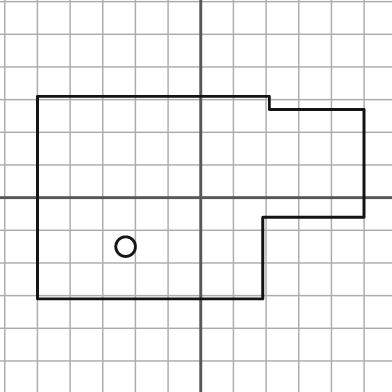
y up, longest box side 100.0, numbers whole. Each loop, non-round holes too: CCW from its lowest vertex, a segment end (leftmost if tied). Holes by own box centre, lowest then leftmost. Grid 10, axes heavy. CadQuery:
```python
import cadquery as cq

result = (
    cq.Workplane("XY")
    .moveTo(-50.0, -31.0)
    .lineTo(19.0, -31.0)
    .lineTo(19.0, -6.0)
    .lineTo(50.0, -6.0)
    .lineTo(50.0, 27.0)
    .lineTo(21.0, 27.0)
    .lineTo(21.0, 31.0)
    .lineTo(-50.0, 31.0)
    .close()
    .moveTo(-23.0, -15.0)
    .circle(3.0)
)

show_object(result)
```